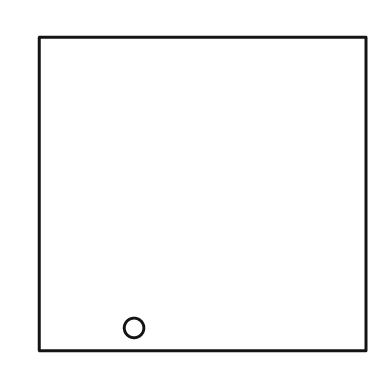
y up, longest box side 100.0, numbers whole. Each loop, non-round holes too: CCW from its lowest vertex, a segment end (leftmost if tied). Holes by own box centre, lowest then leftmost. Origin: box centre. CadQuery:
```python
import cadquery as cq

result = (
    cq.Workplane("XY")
    .moveTo(-50.0, -48.0)
    .lineTo(50.0, -48.0)
    .lineTo(50.0, 48.0)
    .lineTo(-50.0, 48.0)
    .close()
    .moveTo(-21.0, -41.0)
    .circle(3.0)
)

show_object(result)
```